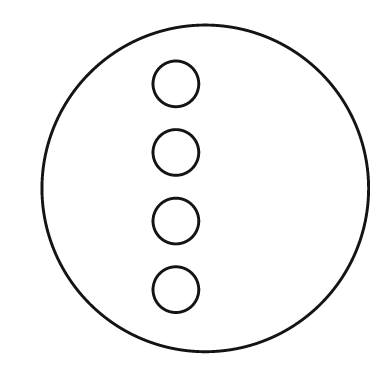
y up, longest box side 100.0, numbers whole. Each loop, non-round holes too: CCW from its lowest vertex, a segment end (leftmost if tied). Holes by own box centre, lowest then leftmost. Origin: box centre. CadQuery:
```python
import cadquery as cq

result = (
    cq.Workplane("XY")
    .moveTo(0.0, 0.0)
    .circle(50.0)
    .moveTo(-9.0, -31.0)
    .circle(7.0)
    .moveTo(-9.0, -10.0)
    .circle(7.0)
    .moveTo(-9.0, 11.0)
    .circle(7.0)
    .moveTo(-9.0, 32.0)
    .circle(7.0)
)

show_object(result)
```